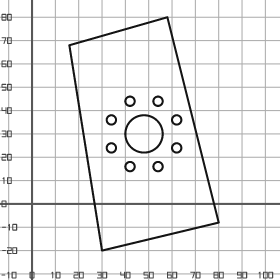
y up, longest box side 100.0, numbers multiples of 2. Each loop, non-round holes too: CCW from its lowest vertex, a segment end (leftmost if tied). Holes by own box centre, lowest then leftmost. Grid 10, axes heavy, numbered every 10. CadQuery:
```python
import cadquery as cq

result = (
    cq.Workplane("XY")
    .moveTo(30.0, -20.0)
    .lineTo(80.0, -8.0)
    .lineTo(58.0, 80.0)
    .lineTo(16.0, 68.0)
    .close()
    .moveTo(42.0, 16.0)
    .circle(2.0)
    .moveTo(54.0, 16.0)
    .circle(2.0)
    .moveTo(34.0, 24.0)
    .circle(2.0)
    .moveTo(62.0, 24.0)
    .circle(2.0)
    .moveTo(48.0, 30.0)
    .circle(8.0)
    .moveTo(34.0, 36.0)
    .circle(2.0)
    .moveTo(62.0, 36.0)
    .circle(2.0)
    .moveTo(42.0, 44.0)
    .circle(2.0)
    .moveTo(54.0, 44.0)
    .circle(2.0)
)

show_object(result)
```